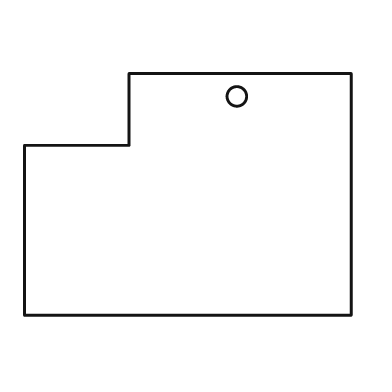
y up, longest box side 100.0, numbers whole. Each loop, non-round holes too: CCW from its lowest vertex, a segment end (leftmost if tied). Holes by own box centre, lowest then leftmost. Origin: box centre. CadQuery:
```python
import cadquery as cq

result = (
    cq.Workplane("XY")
    .moveTo(-50.0, -37.0)
    .lineTo(50.0, -37.0)
    .lineTo(50.0, 37.0)
    .lineTo(-18.0, 37.0)
    .lineTo(-18.0, 15.0)
    .lineTo(-50.0, 15.0)
    .close()
    .moveTo(15.0, 30.0)
    .circle(3.0)
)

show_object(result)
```